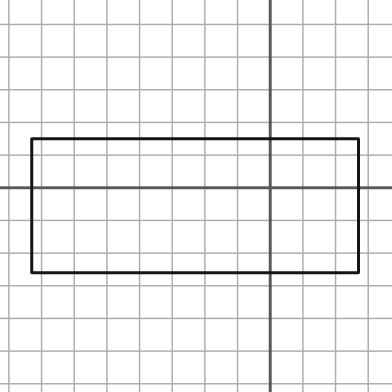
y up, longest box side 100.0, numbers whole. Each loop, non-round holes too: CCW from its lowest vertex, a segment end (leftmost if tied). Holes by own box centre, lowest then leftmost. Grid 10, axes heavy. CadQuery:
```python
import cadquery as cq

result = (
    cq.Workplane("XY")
    .moveTo(-73.0, -26.0)
    .lineTo(27.0, -26.0)
    .lineTo(27.0, 15.0)
    .lineTo(-73.0, 15.0)
    .close()
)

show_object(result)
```